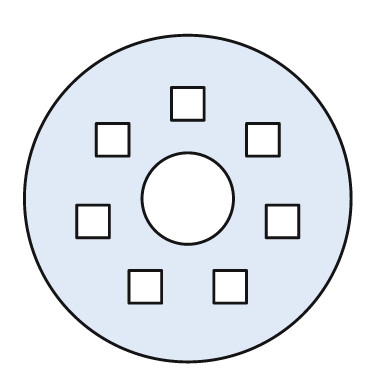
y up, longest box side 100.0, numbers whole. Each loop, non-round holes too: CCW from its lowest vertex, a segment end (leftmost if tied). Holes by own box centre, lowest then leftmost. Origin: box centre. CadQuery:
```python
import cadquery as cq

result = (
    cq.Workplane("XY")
    .moveTo(0.0, 0.0)
    .circle(50.0)
    .moveTo(-18.0, -32.0)
    .lineTo(-8.0, -32.0)
    .lineTo(-8.0, -22.0)
    .lineTo(-18.0, -22.0)
    .close()
    .moveTo(8.0, -32.0)
    .lineTo(18.0, -32.0)
    .lineTo(18.0, -22.0)
    .lineTo(8.0, -22.0)
    .close()
    .moveTo(-34.0, -12.0)
    .lineTo(-24.0, -12.0)
    .lineTo(-24.0, -2.0)
    .lineTo(-34.0, -2.0)
    .close()
    .moveTo(24.0, -12.0)
    .lineTo(34.0, -12.0)
    .lineTo(34.0, -2.0)
    .lineTo(24.0, -2.0)
    .close()
    .moveTo(0.0, 0.0)
    .circle(14.0)
    .moveTo(-28.0, 13.0)
    .lineTo(-18.0, 13.0)
    .lineTo(-18.0, 23.0)
    .lineTo(-28.0, 23.0)
    .close()
    .moveTo(18.0, 13.0)
    .lineTo(28.0, 13.0)
    .lineTo(28.0, 23.0)
    .lineTo(18.0, 23.0)
    .close()
    .moveTo(-5.0, 24.0)
    .lineTo(5.0, 24.0)
    .lineTo(5.0, 34.0)
    .lineTo(-5.0, 34.0)
    .close()
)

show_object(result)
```